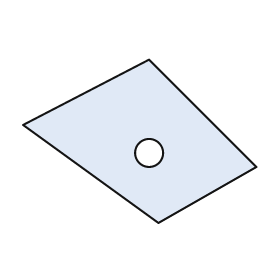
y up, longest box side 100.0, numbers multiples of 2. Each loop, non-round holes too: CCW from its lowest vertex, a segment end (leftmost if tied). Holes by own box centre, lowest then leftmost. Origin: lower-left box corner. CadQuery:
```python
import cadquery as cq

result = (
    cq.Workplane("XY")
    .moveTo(58.0, 0.0)
    .lineTo(100.0, 24.0)
    .lineTo(54.0, 70.0)
    .lineTo(0.0, 42.0)
    .close()
    .moveTo(54.0, 30.0)
    .circle(6.0)
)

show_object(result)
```